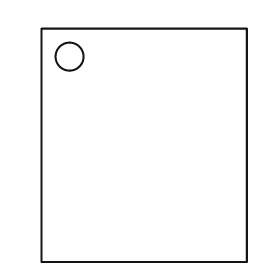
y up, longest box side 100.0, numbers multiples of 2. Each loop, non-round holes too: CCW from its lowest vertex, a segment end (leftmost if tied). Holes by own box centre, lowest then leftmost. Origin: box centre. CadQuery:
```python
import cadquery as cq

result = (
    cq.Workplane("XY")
    .moveTo(-44.0, -50.0)
    .lineTo(44.0, -50.0)
    .lineTo(44.0, 50.0)
    .lineTo(-44.0, 50.0)
    .close()
    .moveTo(-32.0, 38.0)
    .circle(6.0)
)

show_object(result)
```